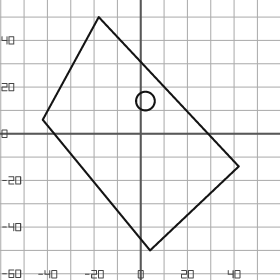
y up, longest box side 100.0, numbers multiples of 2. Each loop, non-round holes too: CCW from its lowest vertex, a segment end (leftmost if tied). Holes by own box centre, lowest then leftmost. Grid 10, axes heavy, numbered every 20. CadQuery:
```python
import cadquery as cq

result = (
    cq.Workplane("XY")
    .moveTo(4.0, -50.0)
    .lineTo(42.0, -14.0)
    .lineTo(-18.0, 50.0)
    .lineTo(-42.0, 6.0)
    .close()
    .moveTo(2.0, 14.0)
    .circle(4.0)
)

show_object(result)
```